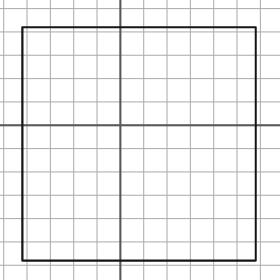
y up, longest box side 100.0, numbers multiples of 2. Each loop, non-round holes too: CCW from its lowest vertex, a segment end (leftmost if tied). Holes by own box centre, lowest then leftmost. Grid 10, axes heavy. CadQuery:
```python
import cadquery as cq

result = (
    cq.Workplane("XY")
    .moveTo(-42.0, -58.0)
    .lineTo(58.0, -58.0)
    .lineTo(58.0, 42.0)
    .lineTo(-42.0, 42.0)
    .close()
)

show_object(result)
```